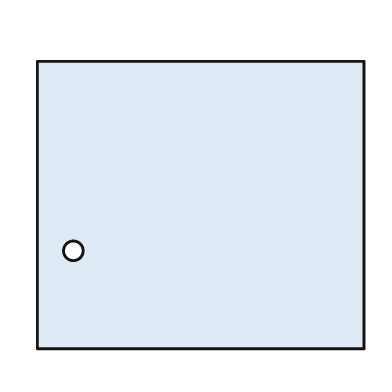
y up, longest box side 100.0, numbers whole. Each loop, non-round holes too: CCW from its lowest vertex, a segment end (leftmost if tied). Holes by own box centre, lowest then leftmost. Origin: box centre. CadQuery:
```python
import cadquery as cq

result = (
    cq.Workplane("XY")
    .moveTo(-50.0, -44.0)
    .lineTo(50.0, -44.0)
    .lineTo(50.0, 44.0)
    .lineTo(-50.0, 44.0)
    .close()
    .moveTo(-39.0, -14.0)
    .circle(3.0)
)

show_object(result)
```